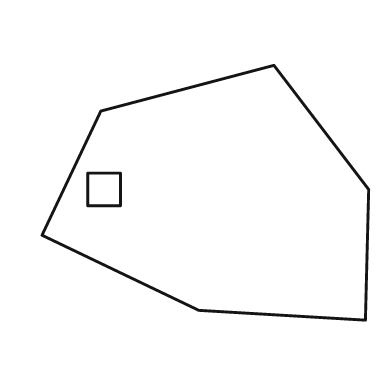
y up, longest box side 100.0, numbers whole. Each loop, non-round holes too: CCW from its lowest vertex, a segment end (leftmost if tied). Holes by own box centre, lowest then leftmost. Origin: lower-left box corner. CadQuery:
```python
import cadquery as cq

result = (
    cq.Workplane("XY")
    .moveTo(99.0, 0.0)
    .lineTo(100.0, 40.0)
    .lineTo(71.0, 78.0)
    .lineTo(18.0, 64.0)
    .lineTo(0.0, 26.0)
    .lineTo(48.0, 3.0)
    .close()
    .moveTo(14.0, 35.0)
    .lineTo(24.0, 35.0)
    .lineTo(24.0, 45.0)
    .lineTo(14.0, 45.0)
    .close()
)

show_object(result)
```